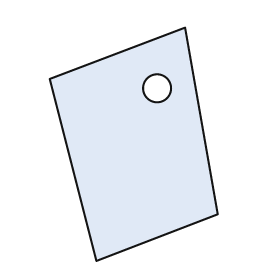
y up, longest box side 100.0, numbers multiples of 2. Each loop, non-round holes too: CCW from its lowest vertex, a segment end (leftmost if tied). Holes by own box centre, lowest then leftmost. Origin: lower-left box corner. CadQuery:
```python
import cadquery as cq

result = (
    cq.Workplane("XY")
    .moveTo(20.0, 0.0)
    .lineTo(72.0, 20.0)
    .lineTo(58.0, 100.0)
    .lineTo(0.0, 78.0)
    .close()
    .moveTo(46.0, 74.0)
    .circle(6.0)
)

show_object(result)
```